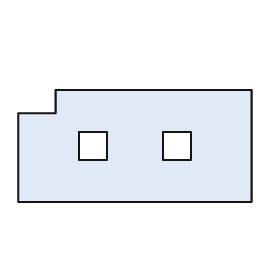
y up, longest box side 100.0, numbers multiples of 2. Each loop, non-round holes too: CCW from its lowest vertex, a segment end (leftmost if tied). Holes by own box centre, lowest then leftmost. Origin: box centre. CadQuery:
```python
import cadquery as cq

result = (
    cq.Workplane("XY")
    .moveTo(-50.0, -24.0)
    .lineTo(50.0, -24.0)
    .lineTo(50.0, 24.0)
    .lineTo(-34.0, 24.0)
    .lineTo(-34.0, 14.0)
    .lineTo(-50.0, 14.0)
    .close()
    .moveTo(-24.0, -6.0)
    .lineTo(-12.0, -6.0)
    .lineTo(-12.0, 6.0)
    .lineTo(-24.0, 6.0)
    .close()
    .moveTo(12.0, -6.0)
    .lineTo(24.0, -6.0)
    .lineTo(24.0, 6.0)
    .lineTo(12.0, 6.0)
    .close()
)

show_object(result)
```